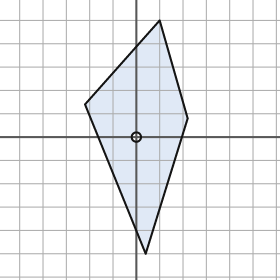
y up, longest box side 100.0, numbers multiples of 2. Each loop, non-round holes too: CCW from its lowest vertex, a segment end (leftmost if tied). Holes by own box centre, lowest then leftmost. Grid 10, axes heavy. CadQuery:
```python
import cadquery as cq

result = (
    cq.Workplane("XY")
    .moveTo(4.0, -50.0)
    .lineTo(22.0, 8.0)
    .lineTo(10.0, 50.0)
    .lineTo(-22.0, 14.0)
    .close()
    .moveTo(0.0, 0.0)
    .circle(2.0)
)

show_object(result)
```